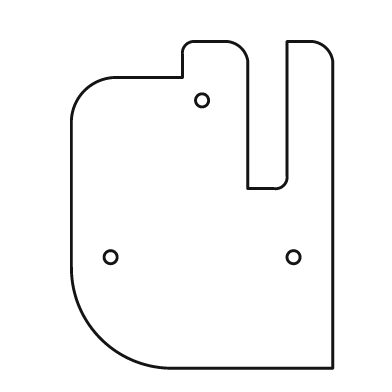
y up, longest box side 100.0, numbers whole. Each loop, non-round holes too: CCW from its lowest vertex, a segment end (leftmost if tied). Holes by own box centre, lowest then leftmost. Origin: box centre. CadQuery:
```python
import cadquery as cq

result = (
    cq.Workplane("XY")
    .moveTo(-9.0, -50.0)
    .lineTo(40.0, -50.0)
    .lineTo(40.0, 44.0)
    .threePointArc((38.0, 48.0), (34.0, 50.0))
    .lineTo(26.0, 50.0)
    .lineTo(26.0, 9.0)
    .threePointArc((25.0, 6.0), (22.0, 5.0))
    .lineTo(14.0, 5.0)
    .lineTo(14.0, 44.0)
    .threePointArc((12.0, 48.0), (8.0, 50.0))
    .lineTo(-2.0, 50.0)
    .threePointArc((-5.0, 49.0), (-6.0, 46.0))
    .lineTo(-6.0, 39.0)
    .lineTo(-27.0, 39.0)
    .threePointArc((-36.0, 35.0), (-40.0, 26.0))
    .lineTo(-40.0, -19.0)
    .threePointArc((-31.0, -41.0), (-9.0, -50.0))
    .close()
    .moveTo(-28.0, -16.0)
    .circle(2.0)
    .moveTo(28.0, -16.0)
    .circle(2.0)
    .moveTo(0.0, 32.0)
    .circle(2.0)
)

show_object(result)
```